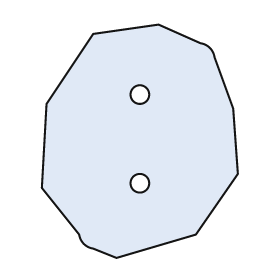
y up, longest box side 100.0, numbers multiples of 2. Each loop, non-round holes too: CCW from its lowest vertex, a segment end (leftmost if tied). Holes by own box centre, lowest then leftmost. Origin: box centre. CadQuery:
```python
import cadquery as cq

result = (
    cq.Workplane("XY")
    .moveTo(-10.0, -50.0)
    .lineTo(24.0, -40.0)
    .lineTo(42.0, -14.0)
    .lineTo(40.0, 14.0)
    .lineTo(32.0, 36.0)
    .threePointArc((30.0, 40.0), (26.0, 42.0))
    .lineTo(8.0, 50.0)
    .lineTo(-20.0, 46.0)
    .lineTo(-40.0, 16.0)
    .lineTo(-42.0, -20.0)
    .lineTo(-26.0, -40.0)
    .threePointArc((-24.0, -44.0), (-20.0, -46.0))
    .close()
    .moveTo(0.0, -18.0)
    .circle(4.0)
    .moveTo(0.0, 20.0)
    .circle(4.0)
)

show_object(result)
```